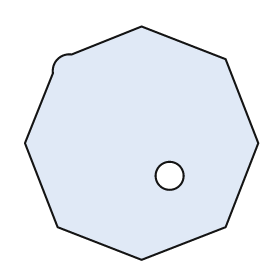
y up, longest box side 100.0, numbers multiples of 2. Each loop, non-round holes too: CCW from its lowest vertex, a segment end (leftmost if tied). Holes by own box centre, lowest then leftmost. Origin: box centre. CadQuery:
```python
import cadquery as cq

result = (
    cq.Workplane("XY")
    .moveTo(0.0, -50.0)
    .lineTo(36.0, -36.0)
    .lineTo(50.0, 0.0)
    .lineTo(36.0, 36.0)
    .lineTo(0.0, 50.0)
    .lineTo(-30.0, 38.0)
    .threePointArc((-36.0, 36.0), (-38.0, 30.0))
    .lineTo(-50.0, 0.0)
    .lineTo(-36.0, -36.0)
    .close()
    .moveTo(12.0, -14.0)
    .circle(6.0)
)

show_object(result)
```